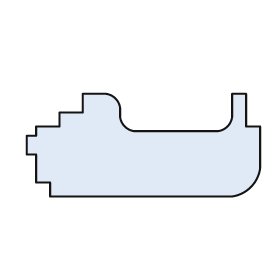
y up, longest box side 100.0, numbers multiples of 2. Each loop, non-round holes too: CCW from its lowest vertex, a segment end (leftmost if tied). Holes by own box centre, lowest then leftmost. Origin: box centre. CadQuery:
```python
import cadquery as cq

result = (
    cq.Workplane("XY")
    .moveTo(-40.0, -22.0)
    .lineTo(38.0, -22.0)
    .threePointArc((46.0, -18.0), (50.0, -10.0))
    .lineTo(50.0, 8.0)
    .lineTo(44.0, 8.0)
    .lineTo(44.0, 22.0)
    .lineTo(38.0, 22.0)
    .lineTo(38.0, 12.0)
    .threePointArc((36.0, 8.0), (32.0, 6.0))
    .lineTo(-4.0, 6.0)
    .threePointArc((-8.0, 8.0), (-10.0, 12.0))
    .lineTo(-10.0, 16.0)
    .threePointArc((-12.0, 20.0), (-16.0, 22.0))
    .lineTo(-26.0, 22.0)
    .lineTo(-26.0, 14.0)
    .lineTo(-36.0, 14.0)
    .lineTo(-36.0, 8.0)
    .lineTo(-46.0, 8.0)
    .lineTo(-46.0, 4.0)
    .lineTo(-50.0, 4.0)
    .lineTo(-50.0, -4.0)
    .lineTo(-46.0, -4.0)
    .lineTo(-46.0, -16.0)
    .lineTo(-40.0, -16.0)
    .close()
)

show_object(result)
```